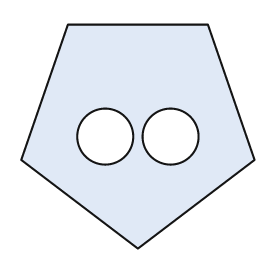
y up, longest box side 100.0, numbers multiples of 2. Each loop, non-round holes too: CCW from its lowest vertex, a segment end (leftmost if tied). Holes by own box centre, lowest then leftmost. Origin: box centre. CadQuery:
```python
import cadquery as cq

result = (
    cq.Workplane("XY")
    .moveTo(0.0, -48.0)
    .lineTo(50.0, -10.0)
    .lineTo(30.0, 48.0)
    .lineTo(-30.0, 48.0)
    .lineTo(-50.0, -10.0)
    .close()
    .moveTo(-14.0, 0.0)
    .circle(12.0)
    .moveTo(14.0, 0.0)
    .circle(12.0)
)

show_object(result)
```